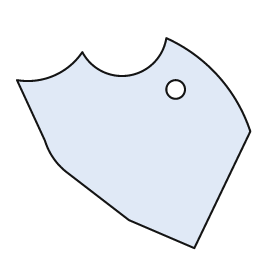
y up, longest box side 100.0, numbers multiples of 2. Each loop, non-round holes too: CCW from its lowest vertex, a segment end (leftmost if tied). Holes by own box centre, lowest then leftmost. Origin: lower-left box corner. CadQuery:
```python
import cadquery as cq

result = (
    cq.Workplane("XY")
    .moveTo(76.0, 0.0)
    .lineTo(100.0, 50.0)
    .threePointArc((86.0, 74.0), (64.0, 90.0))
    .threePointArc((48.0, 74.0), (28.0, 84.0))
    .threePointArc((16.0, 74.0), (0.0, 72.0))
    .lineTo(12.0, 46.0)
    .threePointArc((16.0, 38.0), (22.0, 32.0))
    .lineTo(48.0, 12.0)
    .close()
    .moveTo(68.0, 68.0)
    .circle(4.0)
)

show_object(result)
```